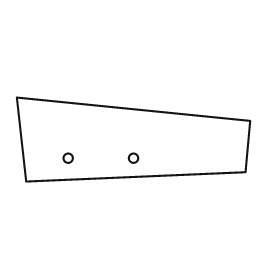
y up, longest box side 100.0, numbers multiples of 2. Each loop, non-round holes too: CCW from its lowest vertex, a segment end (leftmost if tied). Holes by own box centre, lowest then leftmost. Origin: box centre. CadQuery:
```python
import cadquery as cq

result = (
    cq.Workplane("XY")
    .moveTo(-46.0, -18.0)
    .lineTo(48.0, -14.0)
    .lineTo(50.0, 8.0)
    .lineTo(-50.0, 18.0)
    .close()
    .moveTo(-28.0, -8.0)
    .circle(2.0)
    .moveTo(0.0, -8.0)
    .circle(2.0)
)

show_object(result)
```